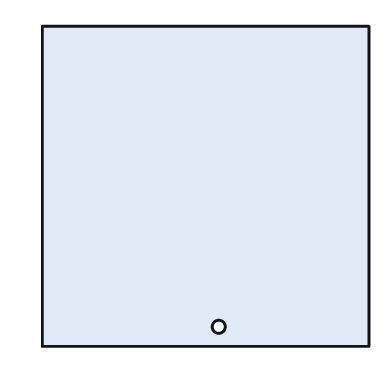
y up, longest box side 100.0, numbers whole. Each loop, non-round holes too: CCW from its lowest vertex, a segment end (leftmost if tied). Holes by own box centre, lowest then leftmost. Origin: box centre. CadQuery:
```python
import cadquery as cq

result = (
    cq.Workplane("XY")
    .moveTo(-50.0, -49.0)
    .lineTo(50.0, -49.0)
    .lineTo(50.0, 49.0)
    .lineTo(-50.0, 49.0)
    .close()
    .moveTo(4.0, -43.0)
    .circle(2.0)
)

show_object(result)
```